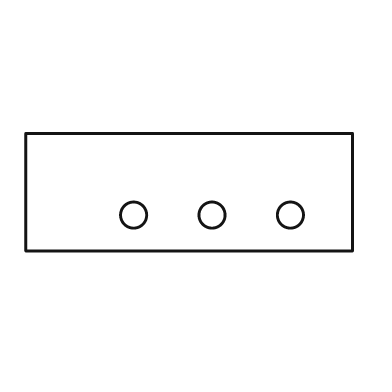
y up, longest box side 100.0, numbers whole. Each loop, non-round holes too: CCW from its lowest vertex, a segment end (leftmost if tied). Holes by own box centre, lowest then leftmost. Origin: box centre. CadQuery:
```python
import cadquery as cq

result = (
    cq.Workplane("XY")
    .moveTo(-50.0, -18.0)
    .lineTo(50.0, -18.0)
    .lineTo(50.0, 18.0)
    .lineTo(-50.0, 18.0)
    .close()
    .moveTo(-17.0, -7.0)
    .circle(4.0)
    .moveTo(7.0, -7.0)
    .circle(4.0)
    .moveTo(31.0, -7.0)
    .circle(4.0)
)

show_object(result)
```